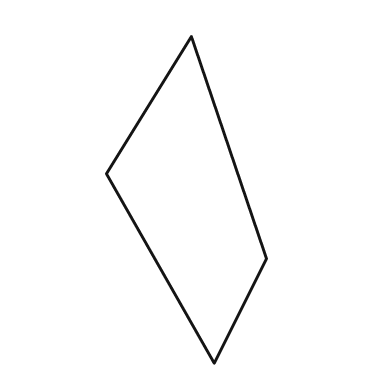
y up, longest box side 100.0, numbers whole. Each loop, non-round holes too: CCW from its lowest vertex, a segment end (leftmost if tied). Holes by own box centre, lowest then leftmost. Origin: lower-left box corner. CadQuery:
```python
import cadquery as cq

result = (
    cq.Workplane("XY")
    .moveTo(33.0, 0.0)
    .lineTo(49.0, 32.0)
    .lineTo(26.0, 100.0)
    .lineTo(0.0, 58.0)
    .close()
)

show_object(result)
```